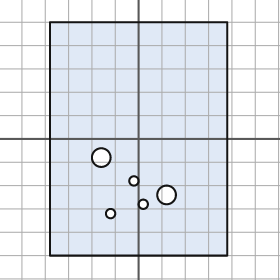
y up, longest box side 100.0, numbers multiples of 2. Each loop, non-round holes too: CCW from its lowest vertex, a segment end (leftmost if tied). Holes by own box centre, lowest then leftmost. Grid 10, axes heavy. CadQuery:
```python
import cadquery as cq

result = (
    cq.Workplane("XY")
    .moveTo(-38.0, -50.0)
    .lineTo(38.0, -50.0)
    .lineTo(38.0, 50.0)
    .lineTo(-38.0, 50.0)
    .close()
    .moveTo(-12.0, -32.0)
    .circle(2.0)
    .moveTo(2.0, -28.0)
    .circle(2.0)
    .moveTo(12.0, -24.0)
    .circle(4.0)
    .moveTo(-2.0, -18.0)
    .circle(2.0)
    .moveTo(-16.0, -8.0)
    .circle(4.0)
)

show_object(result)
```